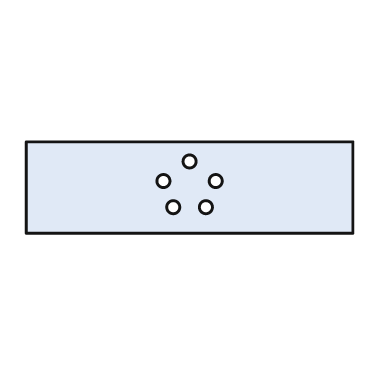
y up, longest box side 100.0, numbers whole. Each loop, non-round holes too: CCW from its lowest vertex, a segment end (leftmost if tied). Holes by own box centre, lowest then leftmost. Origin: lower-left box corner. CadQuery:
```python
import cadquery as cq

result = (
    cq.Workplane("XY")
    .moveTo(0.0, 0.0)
    .lineTo(100.0, 0.0)
    .lineTo(100.0, 28.0)
    .lineTo(0.0, 28.0)
    .close()
    .moveTo(45.0, 8.0)
    .circle(2.0)
    .moveTo(55.0, 8.0)
    .circle(2.0)
    .moveTo(42.0, 16.0)
    .circle(2.0)
    .moveTo(58.0, 16.0)
    .circle(2.0)
    .moveTo(50.0, 22.0)
    .circle(2.0)
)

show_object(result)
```